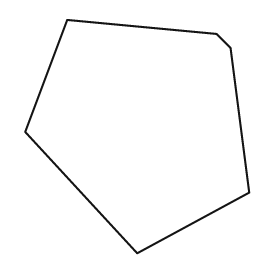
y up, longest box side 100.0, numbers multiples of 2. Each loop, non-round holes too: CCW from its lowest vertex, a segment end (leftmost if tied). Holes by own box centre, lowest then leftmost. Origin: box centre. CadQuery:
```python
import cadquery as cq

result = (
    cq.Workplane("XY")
    .moveTo(0.0, -50.0)
    .lineTo(48.0, -24.0)
    .lineTo(40.0, 38.0)
    .lineTo(34.0, 44.0)
    .lineTo(-30.0, 50.0)
    .lineTo(-48.0, 2.0)
    .close()
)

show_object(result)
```